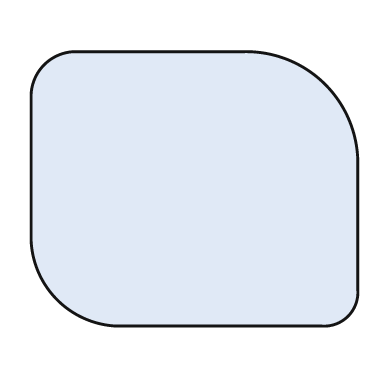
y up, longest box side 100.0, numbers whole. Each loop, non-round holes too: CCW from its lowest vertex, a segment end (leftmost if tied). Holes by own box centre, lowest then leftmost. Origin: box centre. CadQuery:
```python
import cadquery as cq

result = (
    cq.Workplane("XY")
    .moveTo(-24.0, -42.0)
    .lineTo(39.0, -42.0)
    .threePointArc((47.0, -39.0), (50.0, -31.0))
    .lineTo(50.0, 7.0)
    .threePointArc((40.0, 32.0), (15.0, 42.0))
    .lineTo(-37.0, 42.0)
    .threePointArc((-46.0, 38.0), (-50.0, 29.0))
    .lineTo(-50.0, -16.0)
    .threePointArc((-42.0, -34.0), (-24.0, -42.0))
    .close()
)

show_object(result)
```